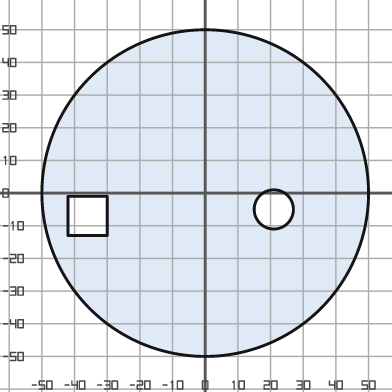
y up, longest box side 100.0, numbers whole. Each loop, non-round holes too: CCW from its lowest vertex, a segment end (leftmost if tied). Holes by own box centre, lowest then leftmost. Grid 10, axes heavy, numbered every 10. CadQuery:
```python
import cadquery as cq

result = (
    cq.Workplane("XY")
    .moveTo(0.0, 0.0)
    .circle(50.0)
    .moveTo(-42.0, -13.0)
    .lineTo(-30.0, -13.0)
    .lineTo(-30.0, -1.0)
    .lineTo(-42.0, -1.0)
    .close()
    .moveTo(21.0, -5.0)
    .circle(6.0)
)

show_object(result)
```